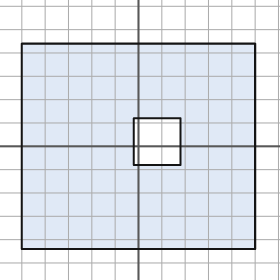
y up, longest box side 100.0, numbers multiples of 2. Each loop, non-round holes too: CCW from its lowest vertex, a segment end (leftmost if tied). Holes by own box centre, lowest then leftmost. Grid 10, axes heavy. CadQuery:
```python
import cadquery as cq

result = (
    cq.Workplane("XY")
    .moveTo(-50.0, -44.0)
    .lineTo(50.0, -44.0)
    .lineTo(50.0, 44.0)
    .lineTo(-50.0, 44.0)
    .close()
    .moveTo(-2.0, -8.0)
    .lineTo(18.0, -8.0)
    .lineTo(18.0, 12.0)
    .lineTo(-2.0, 12.0)
    .close()
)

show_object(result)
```